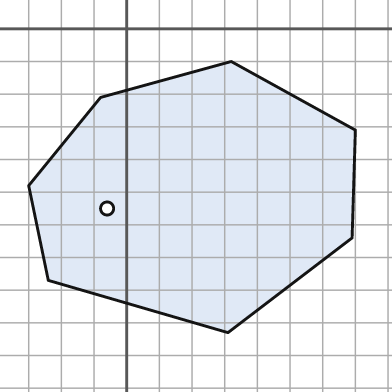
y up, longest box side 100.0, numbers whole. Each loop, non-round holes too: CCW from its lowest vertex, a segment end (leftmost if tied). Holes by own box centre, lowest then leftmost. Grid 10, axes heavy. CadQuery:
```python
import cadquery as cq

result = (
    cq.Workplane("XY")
    .moveTo(31.0, -93.0)
    .lineTo(69.0, -64.0)
    .lineTo(70.0, -31.0)
    .lineTo(32.0, -10.0)
    .lineTo(-8.0, -21.0)
    .lineTo(-30.0, -48.0)
    .lineTo(-24.0, -77.0)
    .close()
    .moveTo(-6.0, -55.0)
    .circle(2.0)
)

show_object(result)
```